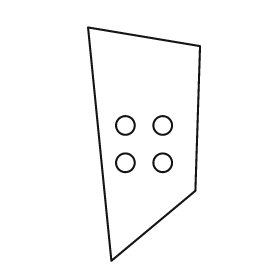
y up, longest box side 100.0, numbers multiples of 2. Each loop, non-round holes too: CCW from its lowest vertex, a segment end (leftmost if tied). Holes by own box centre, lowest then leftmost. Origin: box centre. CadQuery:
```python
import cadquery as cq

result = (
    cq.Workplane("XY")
    .moveTo(-14.0, -50.0)
    .lineTo(22.0, -20.0)
    .lineTo(24.0, 42.0)
    .lineTo(-24.0, 50.0)
    .close()
    .moveTo(-8.0, -8.0)
    .circle(4.0)
    .moveTo(8.0, -8.0)
    .circle(4.0)
    .moveTo(-8.0, 8.0)
    .circle(4.0)
    .moveTo(8.0, 8.0)
    .circle(4.0)
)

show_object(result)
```